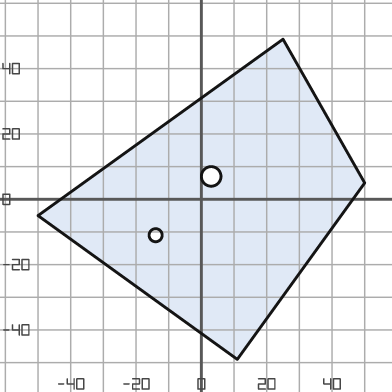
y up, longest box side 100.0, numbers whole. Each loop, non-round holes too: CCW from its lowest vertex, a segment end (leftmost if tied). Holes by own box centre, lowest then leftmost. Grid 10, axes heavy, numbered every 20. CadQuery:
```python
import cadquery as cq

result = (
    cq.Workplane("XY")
    .moveTo(11.0, -49.0)
    .lineTo(50.0, 5.0)
    .lineTo(25.0, 49.0)
    .lineTo(-50.0, -5.0)
    .close()
    .moveTo(-14.0, -11.0)
    .circle(2.0)
    .moveTo(3.0, 7.0)
    .circle(3.0)
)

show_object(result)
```